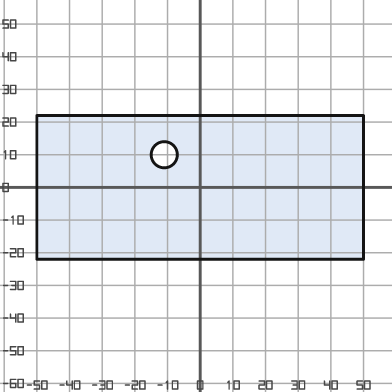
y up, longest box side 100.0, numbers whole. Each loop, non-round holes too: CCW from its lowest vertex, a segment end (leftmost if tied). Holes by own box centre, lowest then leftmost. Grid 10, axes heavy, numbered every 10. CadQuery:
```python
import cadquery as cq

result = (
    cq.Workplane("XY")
    .moveTo(-50.0, -22.0)
    .lineTo(50.0, -22.0)
    .lineTo(50.0, 22.0)
    .lineTo(-50.0, 22.0)
    .close()
    .moveTo(-11.0, 10.0)
    .circle(4.0)
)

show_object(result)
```